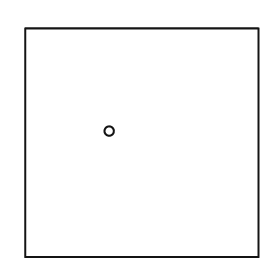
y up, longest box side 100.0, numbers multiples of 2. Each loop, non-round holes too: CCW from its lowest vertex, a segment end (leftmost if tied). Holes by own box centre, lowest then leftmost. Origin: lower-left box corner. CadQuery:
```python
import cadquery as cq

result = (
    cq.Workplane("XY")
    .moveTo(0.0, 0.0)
    .lineTo(100.0, 0.0)
    .lineTo(100.0, 98.0)
    .lineTo(0.0, 98.0)
    .close()
    .moveTo(36.0, 54.0)
    .circle(2.0)
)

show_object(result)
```